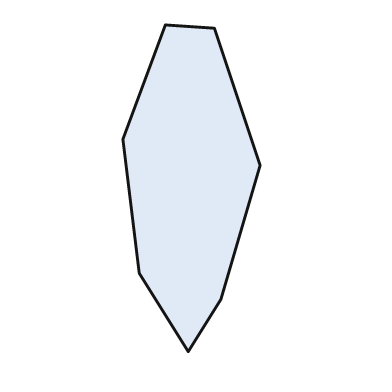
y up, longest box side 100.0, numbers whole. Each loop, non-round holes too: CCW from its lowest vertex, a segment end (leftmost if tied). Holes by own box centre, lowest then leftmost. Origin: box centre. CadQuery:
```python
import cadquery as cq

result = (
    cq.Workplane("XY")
    .moveTo(-1.0, -50.0)
    .lineTo(9.0, -34.0)
    .lineTo(21.0, 7.0)
    .lineTo(7.0, 49.0)
    .lineTo(-8.0, 50.0)
    .lineTo(-21.0, 15.0)
    .lineTo(-16.0, -26.0)
    .close()
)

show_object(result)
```